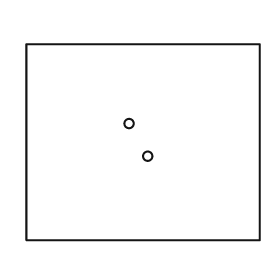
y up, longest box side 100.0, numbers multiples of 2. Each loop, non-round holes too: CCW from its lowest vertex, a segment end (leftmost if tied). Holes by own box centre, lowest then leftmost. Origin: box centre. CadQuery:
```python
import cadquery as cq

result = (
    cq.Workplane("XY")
    .moveTo(-50.0, -42.0)
    .lineTo(50.0, -42.0)
    .lineTo(50.0, 42.0)
    .lineTo(-50.0, 42.0)
    .close()
    .moveTo(2.0, -6.0)
    .circle(2.0)
    .moveTo(-6.0, 8.0)
    .circle(2.0)
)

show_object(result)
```